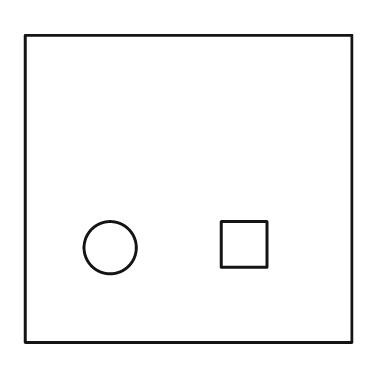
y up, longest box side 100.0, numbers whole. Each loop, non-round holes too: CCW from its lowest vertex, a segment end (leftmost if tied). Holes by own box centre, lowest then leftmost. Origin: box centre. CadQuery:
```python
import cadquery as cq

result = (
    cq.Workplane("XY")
    .moveTo(-50.0, -47.0)
    .lineTo(50.0, -47.0)
    .lineTo(50.0, 47.0)
    .lineTo(-50.0, 47.0)
    .close()
    .moveTo(-24.0, -18.0)
    .circle(8.0)
    .moveTo(10.0, -24.0)
    .lineTo(24.0, -24.0)
    .lineTo(24.0, -10.0)
    .lineTo(10.0, -10.0)
    .close()
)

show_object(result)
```